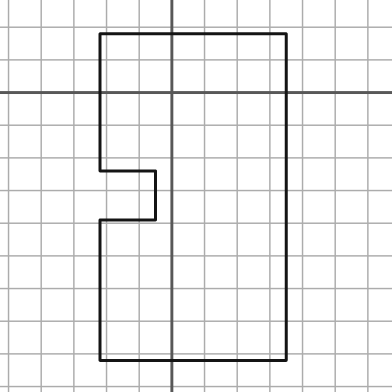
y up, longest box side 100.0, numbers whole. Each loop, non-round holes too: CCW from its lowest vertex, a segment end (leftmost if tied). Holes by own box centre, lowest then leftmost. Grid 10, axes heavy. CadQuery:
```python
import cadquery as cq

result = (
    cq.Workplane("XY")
    .moveTo(-22.0, -82.0)
    .lineTo(35.0, -82.0)
    .lineTo(35.0, 18.0)
    .lineTo(-22.0, 18.0)
    .lineTo(-22.0, -24.0)
    .lineTo(-5.0, -24.0)
    .lineTo(-5.0, -39.0)
    .lineTo(-22.0, -39.0)
    .close()
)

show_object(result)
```